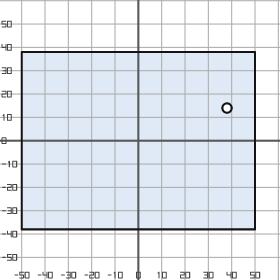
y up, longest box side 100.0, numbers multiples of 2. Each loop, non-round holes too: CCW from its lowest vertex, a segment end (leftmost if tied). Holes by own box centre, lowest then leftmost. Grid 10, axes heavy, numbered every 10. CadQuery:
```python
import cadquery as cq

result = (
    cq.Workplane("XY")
    .moveTo(-50.0, -38.0)
    .lineTo(50.0, -38.0)
    .lineTo(50.0, 38.0)
    .lineTo(-50.0, 38.0)
    .close()
    .moveTo(38.0, 14.0)
    .circle(2.0)
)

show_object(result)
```